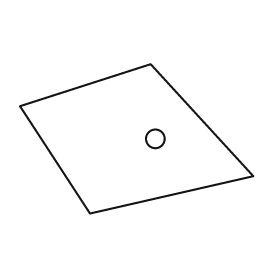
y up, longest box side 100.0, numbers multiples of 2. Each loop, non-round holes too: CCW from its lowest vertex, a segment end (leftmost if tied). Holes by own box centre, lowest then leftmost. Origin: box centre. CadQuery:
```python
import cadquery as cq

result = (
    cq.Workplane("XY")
    .moveTo(-20.0, -32.0)
    .lineTo(50.0, -16.0)
    .lineTo(6.0, 32.0)
    .lineTo(-50.0, 14.0)
    .close()
    .moveTo(8.0, 0.0)
    .circle(4.0)
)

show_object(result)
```